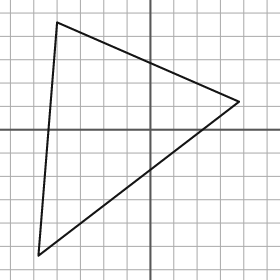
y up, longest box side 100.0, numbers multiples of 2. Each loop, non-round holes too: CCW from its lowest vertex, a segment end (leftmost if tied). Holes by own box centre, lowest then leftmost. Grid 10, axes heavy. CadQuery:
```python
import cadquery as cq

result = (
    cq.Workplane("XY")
    .moveTo(-48.0, -54.0)
    .lineTo(38.0, 12.0)
    .lineTo(-40.0, 46.0)
    .close()
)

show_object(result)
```